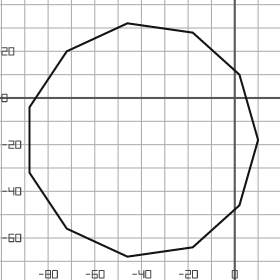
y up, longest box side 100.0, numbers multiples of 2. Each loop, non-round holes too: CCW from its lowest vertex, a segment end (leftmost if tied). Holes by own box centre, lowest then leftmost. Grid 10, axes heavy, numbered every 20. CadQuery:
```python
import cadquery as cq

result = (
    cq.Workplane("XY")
    .moveTo(-46.0, -68.0)
    .lineTo(-18.0, -64.0)
    .lineTo(2.0, -46.0)
    .lineTo(10.0, -18.0)
    .lineTo(2.0, 10.0)
    .lineTo(-18.0, 28.0)
    .lineTo(-46.0, 32.0)
    .lineTo(-72.0, 20.0)
    .lineTo(-88.0, -4.0)
    .lineTo(-88.0, -32.0)
    .lineTo(-72.0, -56.0)
    .close()
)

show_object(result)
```